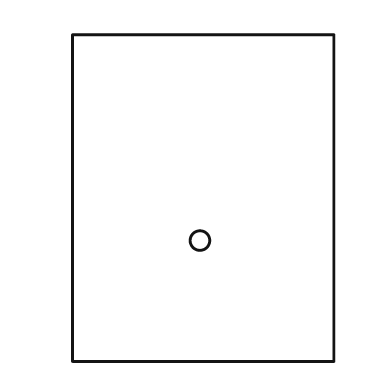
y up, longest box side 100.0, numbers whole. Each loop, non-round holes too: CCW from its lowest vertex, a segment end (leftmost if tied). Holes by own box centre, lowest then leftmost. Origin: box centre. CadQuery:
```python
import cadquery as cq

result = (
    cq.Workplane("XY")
    .moveTo(-40.0, -50.0)
    .lineTo(40.0, -50.0)
    .lineTo(40.0, 50.0)
    .lineTo(-40.0, 50.0)
    .close()
    .moveTo(-1.0, -13.0)
    .circle(3.0)
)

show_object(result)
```